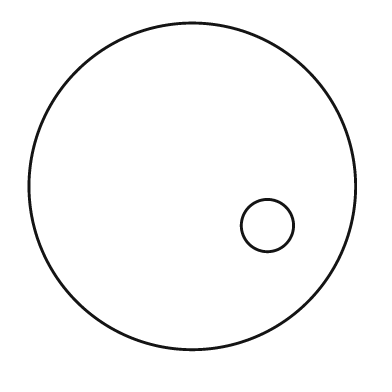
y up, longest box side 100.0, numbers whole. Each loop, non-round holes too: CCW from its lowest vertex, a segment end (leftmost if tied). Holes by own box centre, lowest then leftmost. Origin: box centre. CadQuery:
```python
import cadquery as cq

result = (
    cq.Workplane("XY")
    .moveTo(0.0, 0.0)
    .circle(50.0)
    .moveTo(23.0, -12.0)
    .circle(8.0)
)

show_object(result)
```